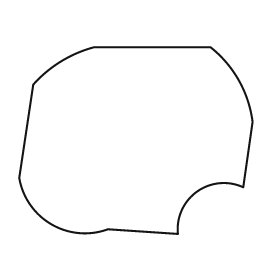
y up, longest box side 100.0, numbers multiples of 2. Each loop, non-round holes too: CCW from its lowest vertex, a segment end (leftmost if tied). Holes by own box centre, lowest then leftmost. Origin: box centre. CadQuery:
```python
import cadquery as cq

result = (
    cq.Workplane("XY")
    .moveTo(18.0, -40.0)
    .threePointArc((26.0, -22.0), (46.0, -20.0))
    .lineTo(50.0, 8.0)
    .threePointArc((44.0, 26.0), (32.0, 40.0))
    .lineTo(-18.0, 40.0)
    .threePointArc((-32.0, 34.0), (-44.0, 24.0))
    .lineTo(-50.0, -16.0)
    .threePointArc((-36.0, -36.0), (-12.0, -38.0))
    .close()
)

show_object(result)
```